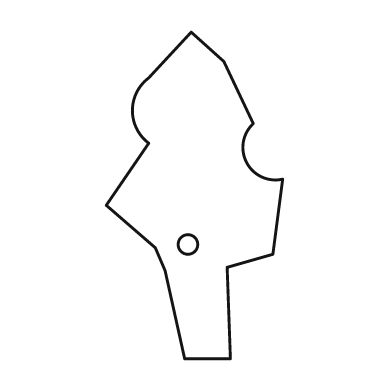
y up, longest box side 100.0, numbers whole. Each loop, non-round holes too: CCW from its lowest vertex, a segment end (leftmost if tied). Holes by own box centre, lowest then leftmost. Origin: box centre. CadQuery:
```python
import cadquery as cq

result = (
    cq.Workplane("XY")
    .moveTo(-3.0, -50.0)
    .lineTo(11.0, -50.0)
    .lineTo(10.0, -22.0)
    .lineTo(24.0, -18.0)
    .lineTo(27.0, 5.0)
    .threePointArc((16.0, 10.0), (18.0, 22.0))
    .lineTo(9.0, 41.0)
    .lineTo(-1.0, 50.0)
    .lineTo(-14.0, 36.0)
    .threePointArc((-19.0, 26.0), (-14.0, 16.0))
    .lineTo(-27.0, -3.0)
    .lineTo(-12.0, -16.0)
    .lineTo(-9.0, -23.0)
    .close()
    .moveTo(-2.0, -15.0)
    .circle(3.0)
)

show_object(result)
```